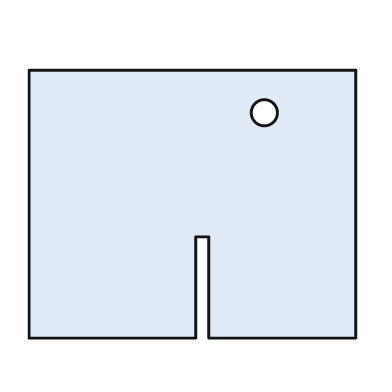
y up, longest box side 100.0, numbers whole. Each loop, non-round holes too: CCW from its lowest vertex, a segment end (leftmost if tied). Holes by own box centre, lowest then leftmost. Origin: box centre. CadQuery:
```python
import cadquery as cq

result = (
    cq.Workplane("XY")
    .moveTo(-50.0, -41.0)
    .lineTo(1.0, -41.0)
    .lineTo(1.0, -10.0)
    .lineTo(5.0, -10.0)
    .lineTo(5.0, -41.0)
    .lineTo(50.0, -41.0)
    .lineTo(50.0, 41.0)
    .lineTo(-50.0, 41.0)
    .close()
    .moveTo(22.0, 28.0)
    .circle(4.0)
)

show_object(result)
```